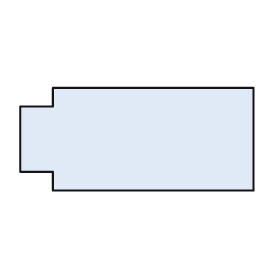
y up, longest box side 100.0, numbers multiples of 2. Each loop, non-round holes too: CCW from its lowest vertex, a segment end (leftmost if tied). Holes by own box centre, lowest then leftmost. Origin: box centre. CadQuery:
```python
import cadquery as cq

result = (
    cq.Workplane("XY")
    .moveTo(-36.0, -22.0)
    .lineTo(50.0, -22.0)
    .lineTo(50.0, 22.0)
    .lineTo(-36.0, 22.0)
    .lineTo(-36.0, 14.0)
    .lineTo(-50.0, 14.0)
    .lineTo(-50.0, -14.0)
    .lineTo(-36.0, -14.0)
    .close()
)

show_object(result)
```